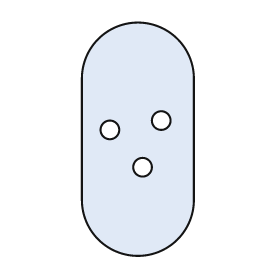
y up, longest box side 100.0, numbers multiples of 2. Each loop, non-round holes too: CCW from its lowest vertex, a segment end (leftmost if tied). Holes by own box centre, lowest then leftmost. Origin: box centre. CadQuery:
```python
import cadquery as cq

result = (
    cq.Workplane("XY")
    .moveTo(-24.0, -26.0)
    .threePointArc((0.0, -50.0), (24.0, -26.0))
    .lineTo(24.0, 26.0)
    .threePointArc((0.0, 50.0), (-24.0, 26.0))
    .close()
    .moveTo(2.0, -12.0)
    .circle(4.0)
    .moveTo(-12.0, 4.0)
    .circle(4.0)
    .moveTo(10.0, 8.0)
    .circle(4.0)
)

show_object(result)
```